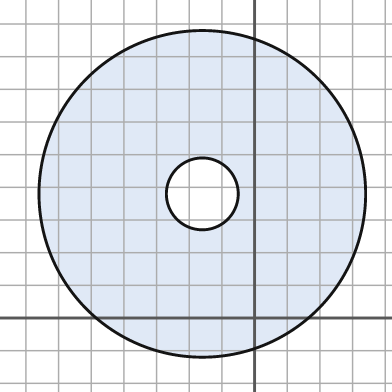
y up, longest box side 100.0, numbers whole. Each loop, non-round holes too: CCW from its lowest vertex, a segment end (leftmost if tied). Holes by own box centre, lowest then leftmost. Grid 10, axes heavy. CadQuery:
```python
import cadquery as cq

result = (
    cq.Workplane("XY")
    .moveTo(-16.0, 38.0)
    .circle(50.0)
    .moveTo(-16.0, 38.0)
    .circle(11.0)
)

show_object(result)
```